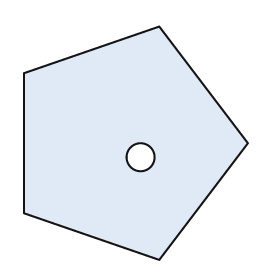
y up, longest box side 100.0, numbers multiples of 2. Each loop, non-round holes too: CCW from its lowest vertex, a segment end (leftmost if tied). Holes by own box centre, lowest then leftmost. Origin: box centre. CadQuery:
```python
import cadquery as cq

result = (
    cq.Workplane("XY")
    .moveTo(10.0, -50.0)
    .lineTo(48.0, 0.0)
    .lineTo(10.0, 50.0)
    .lineTo(-48.0, 30.0)
    .lineTo(-48.0, -30.0)
    .close()
    .moveTo(2.0, -6.0)
    .circle(6.0)
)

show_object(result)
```